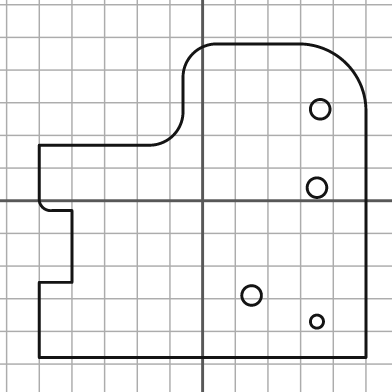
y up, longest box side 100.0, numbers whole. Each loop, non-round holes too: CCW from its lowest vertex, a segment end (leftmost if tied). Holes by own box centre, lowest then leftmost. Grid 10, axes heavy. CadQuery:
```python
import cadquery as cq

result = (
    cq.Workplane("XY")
    .moveTo(-50.0, -48.0)
    .lineTo(50.0, -48.0)
    .lineTo(50.0, 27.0)
    .threePointArc((44.0, 42.0), (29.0, 48.0))
    .lineTo(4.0, 48.0)
    .threePointArc((-3.0, 45.0), (-6.0, 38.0))
    .lineTo(-6.0, 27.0)
    .threePointArc((-9.0, 20.0), (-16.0, 17.0))
    .lineTo(-50.0, 17.0)
    .lineTo(-50.0, 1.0)
    .threePointArc((-49.0, -2.0), (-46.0, -3.0))
    .lineTo(-40.0, -3.0)
    .lineTo(-40.0, -25.0)
    .lineTo(-50.0, -25.0)
    .close()
    .moveTo(35.0, -37.0)
    .circle(2.0)
    .moveTo(15.0, -29.0)
    .circle(3.0)
    .moveTo(35.0, 4.0)
    .circle(3.0)
    .moveTo(36.0, 28.0)
    .circle(3.0)
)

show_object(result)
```